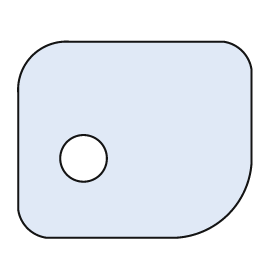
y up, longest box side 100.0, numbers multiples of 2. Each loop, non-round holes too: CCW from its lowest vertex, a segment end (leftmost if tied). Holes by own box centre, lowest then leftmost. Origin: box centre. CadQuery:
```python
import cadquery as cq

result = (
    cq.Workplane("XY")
    .moveTo(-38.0, -42.0)
    .lineTo(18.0, -42.0)
    .threePointArc((40.0, -32.0), (50.0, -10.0))
    .lineTo(50.0, 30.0)
    .threePointArc((46.0, 38.0), (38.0, 42.0))
    .lineTo(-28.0, 42.0)
    .threePointArc((-44.0, 36.0), (-50.0, 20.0))
    .lineTo(-50.0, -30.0)
    .threePointArc((-46.0, -38.0), (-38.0, -42.0))
    .close()
    .moveTo(-22.0, -8.0)
    .circle(10.0)
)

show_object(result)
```